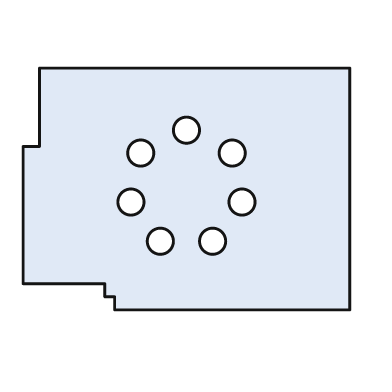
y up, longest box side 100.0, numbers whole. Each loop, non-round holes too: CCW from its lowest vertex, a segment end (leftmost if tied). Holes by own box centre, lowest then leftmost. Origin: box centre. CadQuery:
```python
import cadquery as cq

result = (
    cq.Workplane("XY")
    .moveTo(-22.0, -37.0)
    .lineTo(50.0, -37.0)
    .lineTo(50.0, 37.0)
    .lineTo(-45.0, 37.0)
    .lineTo(-45.0, 13.0)
    .lineTo(-50.0, 13.0)
    .lineTo(-50.0, -29.0)
    .lineTo(-25.0, -29.0)
    .lineTo(-25.0, -33.0)
    .lineTo(-22.0, -33.0)
    .close()
    .moveTo(-8.0, -16.0)
    .circle(4.0)
    .moveTo(8.0, -16.0)
    .circle(4.0)
    .moveTo(-17.0, -4.0)
    .circle(4.0)
    .moveTo(17.0, -4.0)
    .circle(4.0)
    .moveTo(-14.0, 11.0)
    .circle(4.0)
    .moveTo(14.0, 11.0)
    .circle(4.0)
    .moveTo(0.0, 18.0)
    .circle(4.0)
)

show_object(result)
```